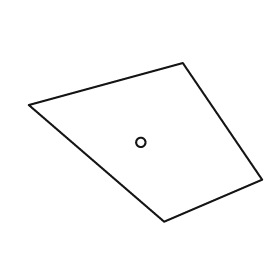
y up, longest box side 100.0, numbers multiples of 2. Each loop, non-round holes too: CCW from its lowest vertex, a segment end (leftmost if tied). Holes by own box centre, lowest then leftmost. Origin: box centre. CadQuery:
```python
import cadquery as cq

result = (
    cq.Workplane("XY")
    .moveTo(8.0, -34.0)
    .lineTo(50.0, -16.0)
    .lineTo(16.0, 34.0)
    .lineTo(-50.0, 16.0)
    .close()
    .moveTo(-2.0, 0.0)
    .circle(2.0)
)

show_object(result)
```